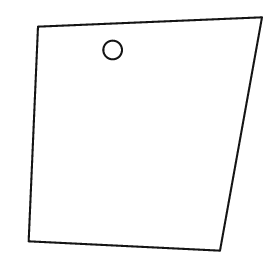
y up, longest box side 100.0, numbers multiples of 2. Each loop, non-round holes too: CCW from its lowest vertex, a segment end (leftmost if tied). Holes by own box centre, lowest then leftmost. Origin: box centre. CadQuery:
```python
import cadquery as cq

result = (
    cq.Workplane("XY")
    .moveTo(32.0, -50.0)
    .lineTo(50.0, 50.0)
    .lineTo(-46.0, 46.0)
    .lineTo(-50.0, -46.0)
    .close()
    .moveTo(-14.0, 36.0)
    .circle(4.0)
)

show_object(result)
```